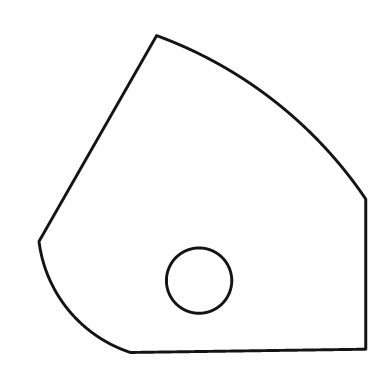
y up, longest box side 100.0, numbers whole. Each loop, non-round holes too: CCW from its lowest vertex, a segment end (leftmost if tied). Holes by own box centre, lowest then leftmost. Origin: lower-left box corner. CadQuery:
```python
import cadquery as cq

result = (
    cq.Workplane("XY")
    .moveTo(28.0, 0.0)
    .lineTo(100.0, 1.0)
    .lineTo(100.0, 47.0)
    .threePointArc((72.0, 77.0), (36.0, 97.0))
    .lineTo(0.0, 34.0)
    .threePointArc((9.0, 13.0), (28.0, 0.0))
    .close()
    .moveTo(49.0, 22.0)
    .circle(10.0)
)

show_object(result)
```